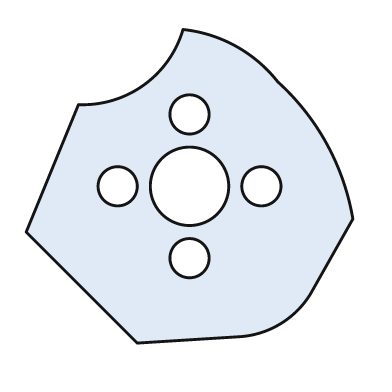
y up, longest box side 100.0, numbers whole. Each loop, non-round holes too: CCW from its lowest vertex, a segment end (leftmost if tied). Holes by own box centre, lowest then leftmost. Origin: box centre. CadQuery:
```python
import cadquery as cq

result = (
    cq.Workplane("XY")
    .moveTo(-16.0, -48.0)
    .lineTo(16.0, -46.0)
    .threePointArc((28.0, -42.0), (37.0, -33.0))
    .lineTo(50.0, -10.0)
    .threePointArc((42.0, 13.0), (27.0, 32.0))
    .threePointArc((14.0, 43.0), (-2.0, 48.0))
    .threePointArc((-14.0, 31.0), (-34.0, 25.0))
    .lineTo(-50.0, -14.0)
    .close()
    .moveTo(0.0, -22.0)
    .circle(6.0)
    .moveTo(-22.0, 0.0)
    .circle(6.0)
    .moveTo(0.0, 0.0)
    .circle(12.0)
    .moveTo(22.0, 0.0)
    .circle(6.0)
    .moveTo(0.0, 22.0)
    .circle(6.0)
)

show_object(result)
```